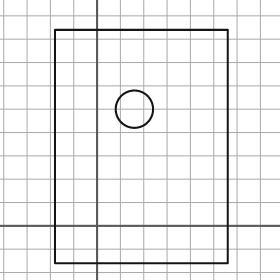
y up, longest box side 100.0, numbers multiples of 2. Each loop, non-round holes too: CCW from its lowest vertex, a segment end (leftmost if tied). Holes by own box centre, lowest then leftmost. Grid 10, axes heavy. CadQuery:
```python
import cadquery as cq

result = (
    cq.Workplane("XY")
    .moveTo(-18.0, -16.0)
    .lineTo(56.0, -16.0)
    .lineTo(56.0, 84.0)
    .lineTo(-18.0, 84.0)
    .close()
    .moveTo(16.0, 50.0)
    .circle(8.0)
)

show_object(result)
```